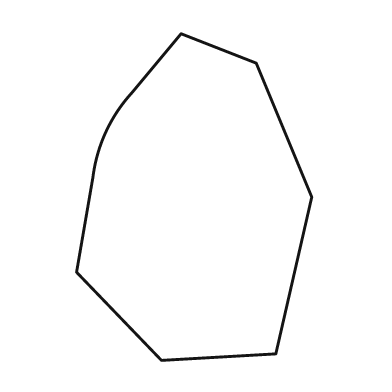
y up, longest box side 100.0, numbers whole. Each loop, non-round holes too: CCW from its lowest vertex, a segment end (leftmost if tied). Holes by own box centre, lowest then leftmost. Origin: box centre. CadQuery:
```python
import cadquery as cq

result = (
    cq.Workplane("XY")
    .moveTo(-10.0, -50.0)
    .lineTo(25.0, -48.0)
    .lineTo(36.0, 0.0)
    .lineTo(19.0, 41.0)
    .lineTo(-4.0, 50.0)
    .lineTo(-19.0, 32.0)
    .threePointArc((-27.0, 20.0), (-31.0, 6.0))
    .lineTo(-36.0, -23.0)
    .close()
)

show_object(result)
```